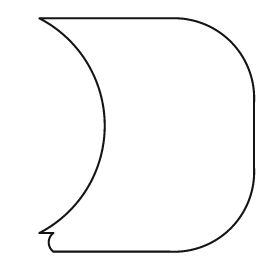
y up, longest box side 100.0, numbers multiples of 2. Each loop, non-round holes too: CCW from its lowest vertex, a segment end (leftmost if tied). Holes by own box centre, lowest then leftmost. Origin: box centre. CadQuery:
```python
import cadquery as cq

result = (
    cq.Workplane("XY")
    .moveTo(-40.0, -50.0)
    .lineTo(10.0, -50.0)
    .threePointArc((36.0, -40.0), (46.0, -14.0))
    .lineTo(46.0, 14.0)
    .threePointArc((36.0, 40.0), (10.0, 50.0))
    .lineTo(-46.0, 50.0)
    .threePointArc((-18.0, 4.0), (-46.0, -42.0))
    .lineTo(-40.0, -42.0)
    .threePointArc((-42.0, -46.0), (-40.0, -50.0))
    .close()
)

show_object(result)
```